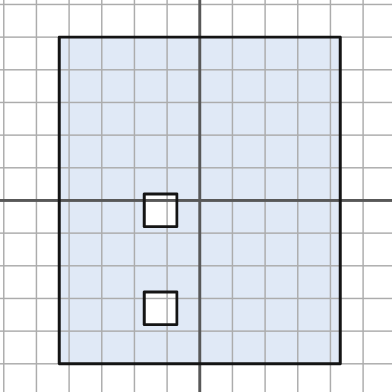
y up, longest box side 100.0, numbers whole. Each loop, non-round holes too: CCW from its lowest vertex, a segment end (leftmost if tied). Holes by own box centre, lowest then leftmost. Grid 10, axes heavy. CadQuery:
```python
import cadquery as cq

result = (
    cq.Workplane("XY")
    .moveTo(-43.0, -50.0)
    .lineTo(43.0, -50.0)
    .lineTo(43.0, 50.0)
    .lineTo(-43.0, 50.0)
    .close()
    .moveTo(-17.0, -38.0)
    .lineTo(-7.0, -38.0)
    .lineTo(-7.0, -28.0)
    .lineTo(-17.0, -28.0)
    .close()
    .moveTo(-17.0, -8.0)
    .lineTo(-7.0, -8.0)
    .lineTo(-7.0, 2.0)
    .lineTo(-17.0, 2.0)
    .close()
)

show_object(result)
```